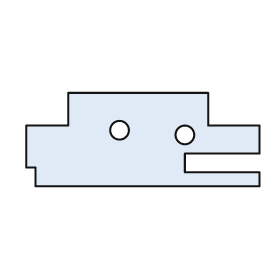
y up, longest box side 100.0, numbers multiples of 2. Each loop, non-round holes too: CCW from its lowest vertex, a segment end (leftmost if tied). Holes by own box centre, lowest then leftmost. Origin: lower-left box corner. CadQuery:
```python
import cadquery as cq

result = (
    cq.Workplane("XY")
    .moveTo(4.0, 0.0)
    .lineTo(100.0, 0.0)
    .lineTo(100.0, 6.0)
    .lineTo(68.0, 6.0)
    .lineTo(68.0, 14.0)
    .lineTo(100.0, 14.0)
    .lineTo(100.0, 26.0)
    .lineTo(78.0, 26.0)
    .lineTo(78.0, 40.0)
    .lineTo(18.0, 40.0)
    .lineTo(18.0, 26.0)
    .lineTo(0.0, 26.0)
    .lineTo(0.0, 8.0)
    .lineTo(4.0, 8.0)
    .close()
    .moveTo(68.0, 22.0)
    .circle(4.0)
    .moveTo(40.0, 24.0)
    .circle(4.0)
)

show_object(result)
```